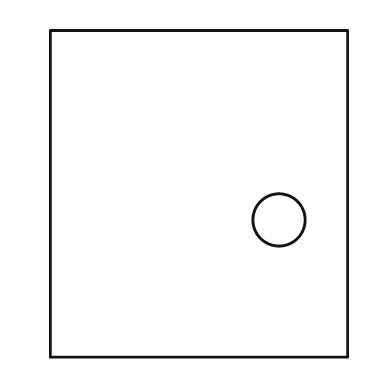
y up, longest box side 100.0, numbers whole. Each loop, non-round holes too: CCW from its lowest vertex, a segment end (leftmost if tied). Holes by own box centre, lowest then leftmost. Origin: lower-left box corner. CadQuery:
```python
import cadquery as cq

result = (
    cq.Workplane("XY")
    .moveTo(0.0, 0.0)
    .lineTo(91.0, 0.0)
    .lineTo(91.0, 100.0)
    .lineTo(0.0, 100.0)
    .close()
    .moveTo(70.0, 42.0)
    .circle(8.0)
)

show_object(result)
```